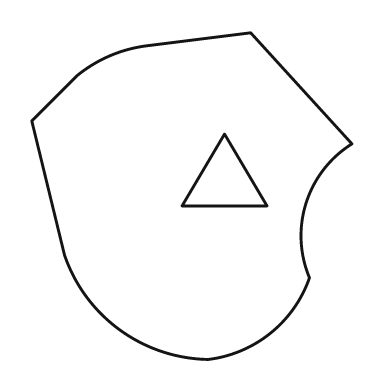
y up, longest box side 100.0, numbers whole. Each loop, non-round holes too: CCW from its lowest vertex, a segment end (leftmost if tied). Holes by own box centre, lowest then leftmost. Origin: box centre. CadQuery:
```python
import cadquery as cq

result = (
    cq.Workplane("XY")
    .moveTo(5.0, -50.0)
    .threePointArc((24.0, -42.0), (36.0, -25.0))
    .threePointArc((35.0, -2.0), (49.0, 16.0))
    .lineTo(18.0, 50.0)
    .lineTo(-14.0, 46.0)
    .threePointArc((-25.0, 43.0), (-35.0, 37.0))
    .lineTo(-49.0, 23.0)
    .lineTo(-39.0, -18.0)
    .threePointArc((-22.0, -41.0), (5.0, -50.0))
    .close()
    .moveTo(-3.0, -3.0)
    .lineTo(23.0, -3.0)
    .lineTo(10.0, 19.0)
    .close()
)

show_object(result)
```